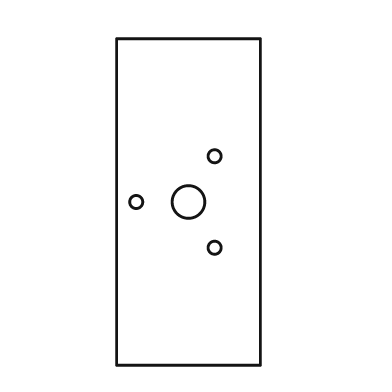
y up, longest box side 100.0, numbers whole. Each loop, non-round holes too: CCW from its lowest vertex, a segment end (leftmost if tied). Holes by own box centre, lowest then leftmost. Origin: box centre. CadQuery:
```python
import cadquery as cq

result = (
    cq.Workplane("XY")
    .moveTo(-22.0, -50.0)
    .lineTo(22.0, -50.0)
    .lineTo(22.0, 50.0)
    .lineTo(-22.0, 50.0)
    .close()
    .moveTo(8.0, -14.0)
    .circle(2.0)
    .moveTo(-16.0, 0.0)
    .circle(2.0)
    .moveTo(0.0, 0.0)
    .circle(5.0)
    .moveTo(8.0, 14.0)
    .circle(2.0)
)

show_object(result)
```